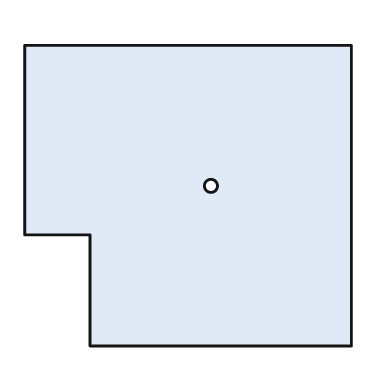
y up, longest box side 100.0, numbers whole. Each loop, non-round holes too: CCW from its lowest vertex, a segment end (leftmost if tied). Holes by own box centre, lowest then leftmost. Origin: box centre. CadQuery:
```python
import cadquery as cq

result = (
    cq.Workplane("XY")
    .moveTo(-30.0, -46.0)
    .lineTo(50.0, -46.0)
    .lineTo(50.0, 46.0)
    .lineTo(-50.0, 46.0)
    .lineTo(-50.0, -12.0)
    .lineTo(-30.0, -12.0)
    .close()
    .moveTo(7.0, 3.0)
    .circle(2.0)
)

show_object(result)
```